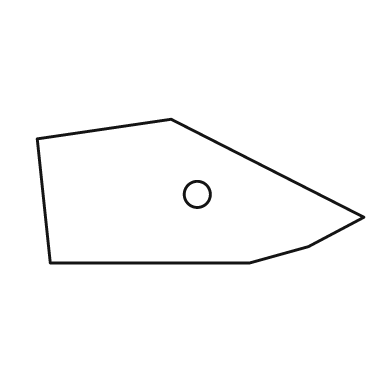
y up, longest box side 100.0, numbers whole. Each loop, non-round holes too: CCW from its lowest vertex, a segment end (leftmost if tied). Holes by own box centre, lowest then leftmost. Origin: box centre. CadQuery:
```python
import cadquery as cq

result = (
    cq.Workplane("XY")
    .moveTo(-46.0, -22.0)
    .lineTo(15.0, -22.0)
    .lineTo(33.0, -17.0)
    .lineTo(50.0, -8.0)
    .lineTo(-9.0, 22.0)
    .lineTo(-50.0, 16.0)
    .close()
    .moveTo(-1.0, -1.0)
    .circle(4.0)
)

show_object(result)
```